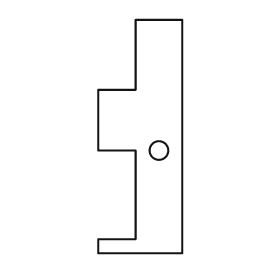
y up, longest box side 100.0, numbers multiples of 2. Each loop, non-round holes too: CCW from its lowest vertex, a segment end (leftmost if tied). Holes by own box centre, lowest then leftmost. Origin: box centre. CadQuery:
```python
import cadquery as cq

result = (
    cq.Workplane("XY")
    .moveTo(-18.0, -50.0)
    .lineTo(18.0, -50.0)
    .lineTo(18.0, 50.0)
    .lineTo(-2.0, 50.0)
    .lineTo(-2.0, 20.0)
    .lineTo(-18.0, 20.0)
    .lineTo(-18.0, -6.0)
    .lineTo(-2.0, -6.0)
    .lineTo(-2.0, -44.0)
    .lineTo(-18.0, -44.0)
    .close()
    .moveTo(8.0, -6.0)
    .circle(4.0)
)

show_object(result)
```